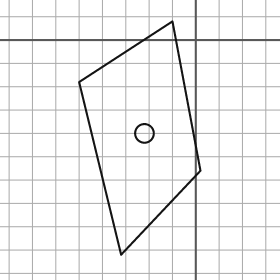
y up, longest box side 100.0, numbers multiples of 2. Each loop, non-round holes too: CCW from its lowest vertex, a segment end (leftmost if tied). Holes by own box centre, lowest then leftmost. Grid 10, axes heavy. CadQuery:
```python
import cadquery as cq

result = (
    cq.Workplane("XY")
    .moveTo(-32.0, -92.0)
    .lineTo(2.0, -56.0)
    .lineTo(-10.0, 8.0)
    .lineTo(-50.0, -18.0)
    .close()
    .moveTo(-22.0, -40.0)
    .circle(4.0)
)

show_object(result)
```